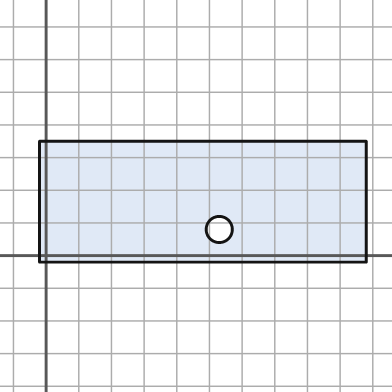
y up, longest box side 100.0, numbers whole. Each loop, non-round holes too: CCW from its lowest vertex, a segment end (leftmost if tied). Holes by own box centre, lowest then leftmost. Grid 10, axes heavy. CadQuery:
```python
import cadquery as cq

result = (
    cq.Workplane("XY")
    .moveTo(-2.0, -2.0)
    .lineTo(98.0, -2.0)
    .lineTo(98.0, 35.0)
    .lineTo(-2.0, 35.0)
    .close()
    .moveTo(53.0, 8.0)
    .circle(4.0)
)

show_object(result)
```